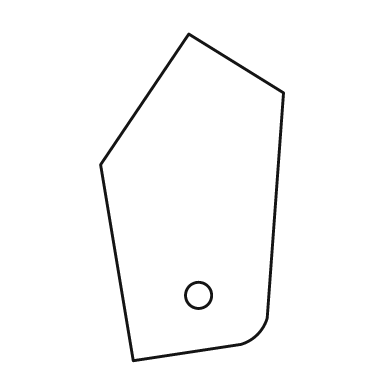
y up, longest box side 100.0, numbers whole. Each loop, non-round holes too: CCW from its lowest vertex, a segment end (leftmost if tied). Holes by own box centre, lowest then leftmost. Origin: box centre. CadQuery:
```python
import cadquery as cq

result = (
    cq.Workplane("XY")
    .moveTo(-18.0, -50.0)
    .lineTo(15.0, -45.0)
    .threePointArc((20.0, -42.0), (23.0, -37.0))
    .lineTo(28.0, 32.0)
    .lineTo(-1.0, 50.0)
    .lineTo(-28.0, 10.0)
    .close()
    .moveTo(2.0, -30.0)
    .circle(4.0)
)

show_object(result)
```